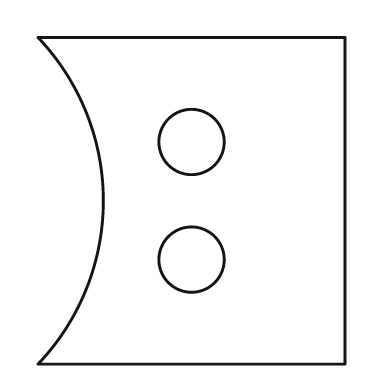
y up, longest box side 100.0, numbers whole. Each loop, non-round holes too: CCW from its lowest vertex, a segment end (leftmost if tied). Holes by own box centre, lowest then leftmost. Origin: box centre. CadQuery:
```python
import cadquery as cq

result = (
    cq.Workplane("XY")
    .moveTo(-47.0, -50.0)
    .lineTo(47.0, -50.0)
    .lineTo(47.0, 50.0)
    .lineTo(-47.0, 50.0)
    .threePointArc((-27.0, 0.0), (-47.0, -50.0))
    .close()
    .moveTo(0.0, -18.0)
    .circle(10.0)
    .moveTo(0.0, 18.0)
    .circle(10.0)
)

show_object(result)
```